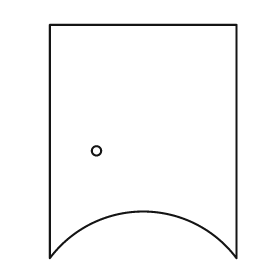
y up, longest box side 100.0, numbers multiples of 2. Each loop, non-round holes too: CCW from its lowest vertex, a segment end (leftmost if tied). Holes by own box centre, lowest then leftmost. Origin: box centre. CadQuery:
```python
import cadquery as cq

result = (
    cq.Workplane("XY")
    .moveTo(-40.0, -50.0)
    .threePointArc((0.0, -30.0), (40.0, -50.0))
    .lineTo(40.0, 50.0)
    .lineTo(-40.0, 50.0)
    .close()
    .moveTo(-20.0, -4.0)
    .circle(2.0)
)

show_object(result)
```